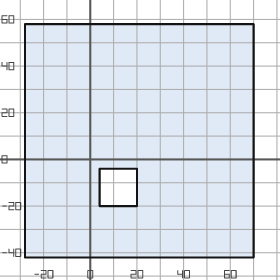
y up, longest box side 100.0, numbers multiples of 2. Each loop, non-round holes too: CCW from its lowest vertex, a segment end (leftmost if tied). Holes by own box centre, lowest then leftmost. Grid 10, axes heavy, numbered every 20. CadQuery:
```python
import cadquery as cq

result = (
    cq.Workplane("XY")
    .moveTo(-28.0, -42.0)
    .lineTo(70.0, -42.0)
    .lineTo(70.0, 58.0)
    .lineTo(-28.0, 58.0)
    .close()
    .moveTo(4.0, -20.0)
    .lineTo(20.0, -20.0)
    .lineTo(20.0, -4.0)
    .lineTo(4.0, -4.0)
    .close()
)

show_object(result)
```